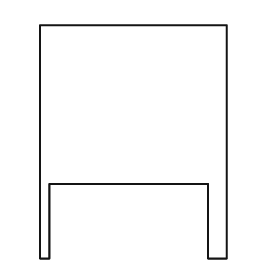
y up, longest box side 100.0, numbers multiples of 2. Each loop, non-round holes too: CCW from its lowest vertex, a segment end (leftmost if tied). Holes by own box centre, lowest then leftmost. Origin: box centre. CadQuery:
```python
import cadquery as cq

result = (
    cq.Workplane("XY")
    .moveTo(-40.0, -50.0)
    .lineTo(-36.0, -50.0)
    .lineTo(-36.0, -18.0)
    .lineTo(32.0, -18.0)
    .lineTo(32.0, -50.0)
    .lineTo(40.0, -50.0)
    .lineTo(40.0, 50.0)
    .lineTo(-40.0, 50.0)
    .close()
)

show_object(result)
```